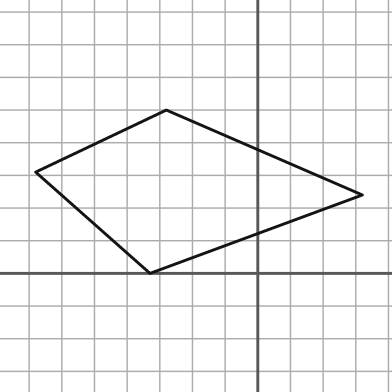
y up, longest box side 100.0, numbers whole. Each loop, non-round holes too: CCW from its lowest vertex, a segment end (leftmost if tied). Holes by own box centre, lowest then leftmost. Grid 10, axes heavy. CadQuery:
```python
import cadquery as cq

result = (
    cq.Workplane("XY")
    .moveTo(-33.0, 0.0)
    .lineTo(32.0, 24.0)
    .lineTo(-28.0, 50.0)
    .lineTo(-68.0, 31.0)
    .close()
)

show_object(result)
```